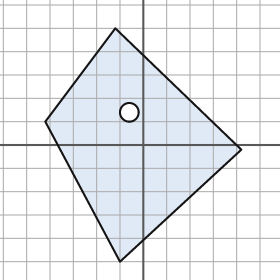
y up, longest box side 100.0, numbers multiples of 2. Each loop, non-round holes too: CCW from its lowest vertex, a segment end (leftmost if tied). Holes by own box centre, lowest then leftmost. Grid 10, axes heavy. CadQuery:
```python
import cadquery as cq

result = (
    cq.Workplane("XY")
    .moveTo(-10.0, -50.0)
    .lineTo(42.0, -2.0)
    .lineTo(-12.0, 50.0)
    .lineTo(-42.0, 10.0)
    .close()
    .moveTo(-6.0, 14.0)
    .circle(4.0)
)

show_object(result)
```